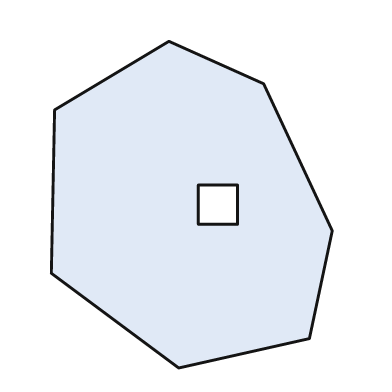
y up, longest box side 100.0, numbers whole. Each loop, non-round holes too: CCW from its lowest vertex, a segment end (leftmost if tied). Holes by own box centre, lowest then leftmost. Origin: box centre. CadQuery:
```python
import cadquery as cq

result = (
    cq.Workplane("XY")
    .moveTo(-4.0, -50.0)
    .lineTo(36.0, -41.0)
    .lineTo(43.0, -8.0)
    .lineTo(22.0, 37.0)
    .lineTo(-7.0, 50.0)
    .lineTo(-42.0, 29.0)
    .lineTo(-43.0, -21.0)
    .close()
    .moveTo(2.0, -6.0)
    .lineTo(14.0, -6.0)
    .lineTo(14.0, 6.0)
    .lineTo(2.0, 6.0)
    .close()
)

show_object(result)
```